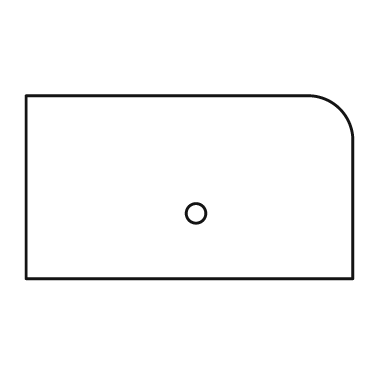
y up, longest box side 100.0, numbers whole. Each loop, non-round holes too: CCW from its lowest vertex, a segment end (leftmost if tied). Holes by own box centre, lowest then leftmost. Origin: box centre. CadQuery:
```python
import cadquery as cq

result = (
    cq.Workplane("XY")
    .moveTo(-50.0, -28.0)
    .lineTo(50.0, -28.0)
    .lineTo(50.0, 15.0)
    .threePointArc((46.0, 24.0), (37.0, 28.0))
    .lineTo(-50.0, 28.0)
    .close()
    .moveTo(2.0, -8.0)
    .circle(3.0)
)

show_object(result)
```